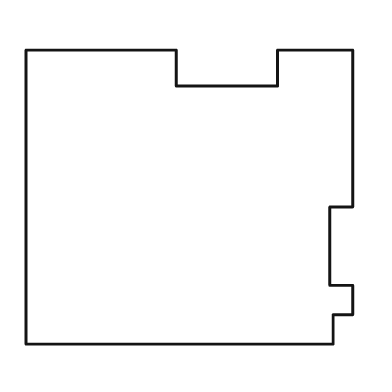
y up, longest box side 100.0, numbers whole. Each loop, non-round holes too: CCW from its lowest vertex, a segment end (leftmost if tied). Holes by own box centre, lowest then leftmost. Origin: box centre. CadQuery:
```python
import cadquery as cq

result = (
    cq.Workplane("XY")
    .moveTo(-50.0, -45.0)
    .lineTo(44.0, -45.0)
    .lineTo(44.0, -36.0)
    .lineTo(50.0, -36.0)
    .lineTo(50.0, -27.0)
    .lineTo(43.0, -27.0)
    .lineTo(43.0, -3.0)
    .lineTo(50.0, -3.0)
    .lineTo(50.0, 45.0)
    .lineTo(27.0, 45.0)
    .lineTo(27.0, 34.0)
    .lineTo(-4.0, 34.0)
    .lineTo(-4.0, 45.0)
    .lineTo(-50.0, 45.0)
    .close()
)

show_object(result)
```